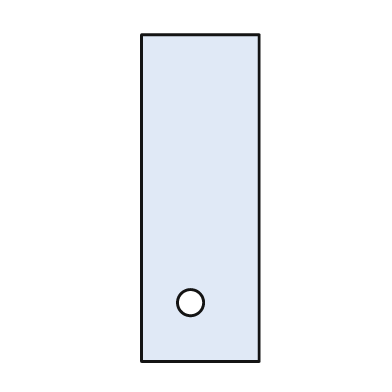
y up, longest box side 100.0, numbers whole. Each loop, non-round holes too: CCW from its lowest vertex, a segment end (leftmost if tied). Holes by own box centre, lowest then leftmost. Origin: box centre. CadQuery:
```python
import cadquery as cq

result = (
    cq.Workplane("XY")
    .moveTo(-18.0, -50.0)
    .lineTo(18.0, -50.0)
    .lineTo(18.0, 50.0)
    .lineTo(-18.0, 50.0)
    .close()
    .moveTo(-3.0, -32.0)
    .circle(4.0)
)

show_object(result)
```